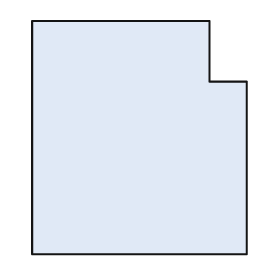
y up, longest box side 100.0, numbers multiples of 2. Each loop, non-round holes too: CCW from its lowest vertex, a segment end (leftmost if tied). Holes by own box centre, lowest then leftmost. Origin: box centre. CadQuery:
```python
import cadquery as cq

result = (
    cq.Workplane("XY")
    .moveTo(-46.0, -50.0)
    .lineTo(46.0, -50.0)
    .lineTo(46.0, 24.0)
    .lineTo(30.0, 24.0)
    .lineTo(30.0, 50.0)
    .lineTo(-46.0, 50.0)
    .close()
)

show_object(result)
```